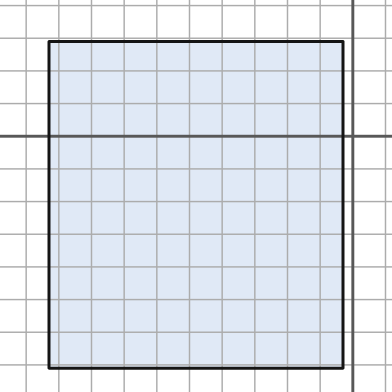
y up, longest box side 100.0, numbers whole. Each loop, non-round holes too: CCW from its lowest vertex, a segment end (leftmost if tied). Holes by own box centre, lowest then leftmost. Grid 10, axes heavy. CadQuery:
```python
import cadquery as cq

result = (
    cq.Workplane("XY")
    .moveTo(-93.0, -71.0)
    .lineTo(-3.0, -71.0)
    .lineTo(-3.0, 29.0)
    .lineTo(-93.0, 29.0)
    .close()
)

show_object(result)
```